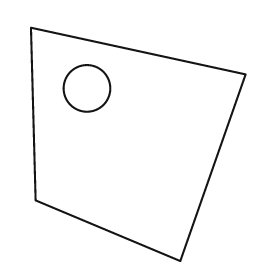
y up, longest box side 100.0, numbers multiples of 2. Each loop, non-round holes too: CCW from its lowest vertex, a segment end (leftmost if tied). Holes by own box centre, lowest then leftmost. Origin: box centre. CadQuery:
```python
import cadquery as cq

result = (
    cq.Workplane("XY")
    .moveTo(18.0, -50.0)
    .lineTo(46.0, 30.0)
    .lineTo(-46.0, 50.0)
    .lineTo(-44.0, -24.0)
    .close()
    .moveTo(-22.0, 24.0)
    .circle(10.0)
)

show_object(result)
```